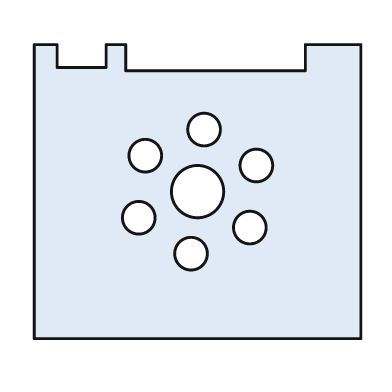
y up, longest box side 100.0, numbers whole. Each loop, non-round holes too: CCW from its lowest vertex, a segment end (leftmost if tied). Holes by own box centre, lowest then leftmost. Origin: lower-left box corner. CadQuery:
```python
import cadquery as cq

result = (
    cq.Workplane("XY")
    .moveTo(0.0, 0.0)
    .lineTo(100.0, 0.0)
    .lineTo(100.0, 90.0)
    .lineTo(83.0, 90.0)
    .lineTo(83.0, 82.0)
    .lineTo(28.0, 82.0)
    .lineTo(28.0, 90.0)
    .lineTo(22.0, 90.0)
    .lineTo(22.0, 83.0)
    .lineTo(7.0, 83.0)
    .lineTo(7.0, 90.0)
    .lineTo(0.0, 90.0)
    .close()
    .moveTo(48.0, 26.0)
    .circle(5.0)
    .moveTo(66.0, 34.0)
    .circle(5.0)
    .moveTo(32.0, 37.0)
    .circle(5.0)
    .moveTo(50.0, 45.0)
    .circle(8.0)
    .moveTo(68.0, 53.0)
    .circle(5.0)
    .moveTo(34.0, 56.0)
    .circle(5.0)
    .moveTo(52.0, 64.0)
    .circle(5.0)
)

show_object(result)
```